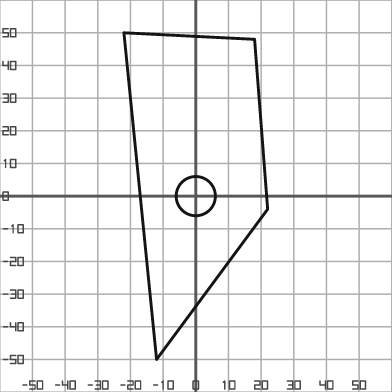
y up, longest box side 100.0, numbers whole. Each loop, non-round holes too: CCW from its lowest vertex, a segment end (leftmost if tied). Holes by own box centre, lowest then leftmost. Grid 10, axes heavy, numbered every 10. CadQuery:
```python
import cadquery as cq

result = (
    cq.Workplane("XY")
    .moveTo(-12.0, -50.0)
    .lineTo(22.0, -4.0)
    .lineTo(18.0, 48.0)
    .lineTo(-22.0, 50.0)
    .close()
    .moveTo(0.0, 0.0)
    .circle(6.0)
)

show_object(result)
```